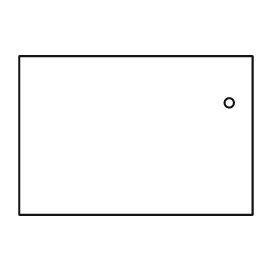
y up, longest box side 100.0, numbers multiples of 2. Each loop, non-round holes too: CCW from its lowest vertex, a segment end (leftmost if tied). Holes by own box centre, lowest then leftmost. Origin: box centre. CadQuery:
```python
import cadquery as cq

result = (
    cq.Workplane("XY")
    .moveTo(-50.0, -34.0)
    .lineTo(50.0, -34.0)
    .lineTo(50.0, 34.0)
    .lineTo(-50.0, 34.0)
    .close()
    .moveTo(40.0, 14.0)
    .circle(2.0)
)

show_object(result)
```